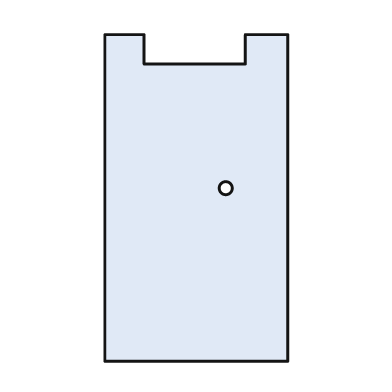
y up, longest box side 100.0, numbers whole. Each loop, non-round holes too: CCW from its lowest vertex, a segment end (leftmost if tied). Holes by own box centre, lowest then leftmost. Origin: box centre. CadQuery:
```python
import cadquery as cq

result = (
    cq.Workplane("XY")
    .moveTo(-28.0, -50.0)
    .lineTo(28.0, -50.0)
    .lineTo(28.0, 50.0)
    .lineTo(15.0, 50.0)
    .lineTo(15.0, 41.0)
    .lineTo(-16.0, 41.0)
    .lineTo(-16.0, 50.0)
    .lineTo(-28.0, 50.0)
    .close()
    .moveTo(9.0, 3.0)
    .circle(2.0)
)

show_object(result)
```